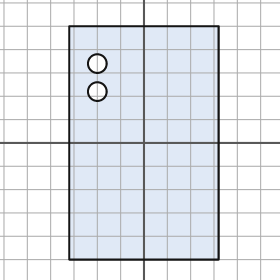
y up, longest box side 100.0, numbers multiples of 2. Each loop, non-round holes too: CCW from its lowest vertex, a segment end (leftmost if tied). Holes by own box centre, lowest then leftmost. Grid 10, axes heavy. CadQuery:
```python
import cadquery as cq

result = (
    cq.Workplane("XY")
    .moveTo(-32.0, -50.0)
    .lineTo(32.0, -50.0)
    .lineTo(32.0, 50.0)
    .lineTo(-32.0, 50.0)
    .close()
    .moveTo(-20.0, 22.0)
    .circle(4.0)
    .moveTo(-20.0, 34.0)
    .circle(4.0)
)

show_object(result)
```